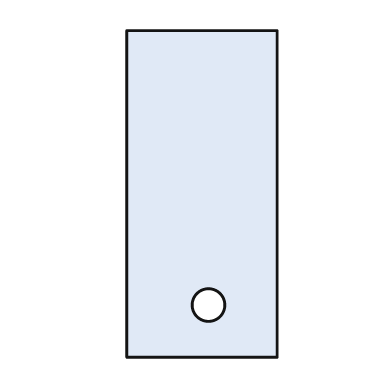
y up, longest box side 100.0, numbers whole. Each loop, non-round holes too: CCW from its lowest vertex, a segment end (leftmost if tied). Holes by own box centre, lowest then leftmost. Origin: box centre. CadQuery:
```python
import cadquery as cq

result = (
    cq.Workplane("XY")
    .moveTo(-23.0, -50.0)
    .lineTo(23.0, -50.0)
    .lineTo(23.0, 50.0)
    .lineTo(-23.0, 50.0)
    .close()
    .moveTo(2.0, -34.0)
    .circle(5.0)
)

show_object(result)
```